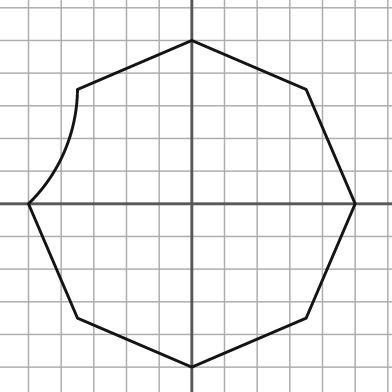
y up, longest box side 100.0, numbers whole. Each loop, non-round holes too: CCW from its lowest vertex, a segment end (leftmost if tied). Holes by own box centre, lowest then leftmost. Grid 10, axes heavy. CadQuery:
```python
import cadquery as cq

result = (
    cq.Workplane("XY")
    .moveTo(0.0, -50.0)
    .lineTo(35.0, -35.0)
    .lineTo(50.0, 0.0)
    .lineTo(35.0, 35.0)
    .lineTo(0.0, 50.0)
    .lineTo(-35.0, 35.0)
    .threePointArc((-39.0, 16.0), (-50.0, 0.0))
    .lineTo(-35.0, -35.0)
    .close()
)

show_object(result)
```